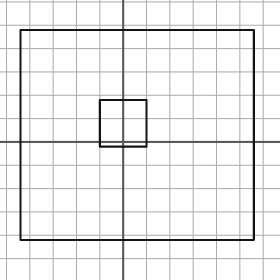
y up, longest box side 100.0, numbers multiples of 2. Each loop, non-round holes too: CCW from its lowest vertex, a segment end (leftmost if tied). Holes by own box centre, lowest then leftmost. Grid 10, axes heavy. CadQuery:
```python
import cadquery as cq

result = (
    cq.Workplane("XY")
    .moveTo(-44.0, -42.0)
    .lineTo(56.0, -42.0)
    .lineTo(56.0, 48.0)
    .lineTo(-44.0, 48.0)
    .close()
    .moveTo(-10.0, -2.0)
    .lineTo(10.0, -2.0)
    .lineTo(10.0, 18.0)
    .lineTo(-10.0, 18.0)
    .close()
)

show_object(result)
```